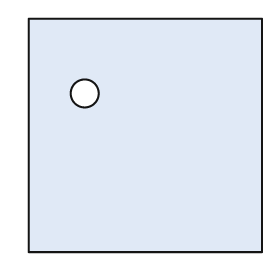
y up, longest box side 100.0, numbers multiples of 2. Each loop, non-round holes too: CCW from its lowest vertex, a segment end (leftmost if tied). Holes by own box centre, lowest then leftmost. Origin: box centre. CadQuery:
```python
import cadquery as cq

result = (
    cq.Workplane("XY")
    .moveTo(-50.0, -50.0)
    .lineTo(50.0, -50.0)
    .lineTo(50.0, 50.0)
    .lineTo(-50.0, 50.0)
    .close()
    .moveTo(-26.0, 18.0)
    .circle(6.0)
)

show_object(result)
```